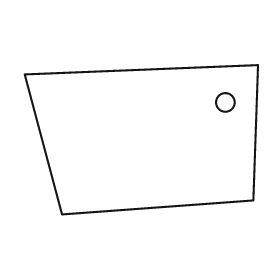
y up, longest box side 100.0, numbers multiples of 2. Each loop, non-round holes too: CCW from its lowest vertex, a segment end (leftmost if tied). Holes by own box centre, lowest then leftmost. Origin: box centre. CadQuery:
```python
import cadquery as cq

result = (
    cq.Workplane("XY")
    .moveTo(-34.0, -32.0)
    .lineTo(48.0, -26.0)
    .lineTo(50.0, 32.0)
    .lineTo(-50.0, 28.0)
    .close()
    .moveTo(36.0, 16.0)
    .circle(4.0)
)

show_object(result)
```